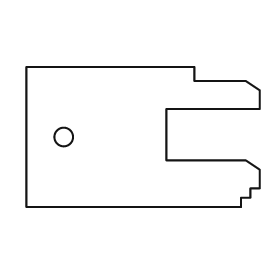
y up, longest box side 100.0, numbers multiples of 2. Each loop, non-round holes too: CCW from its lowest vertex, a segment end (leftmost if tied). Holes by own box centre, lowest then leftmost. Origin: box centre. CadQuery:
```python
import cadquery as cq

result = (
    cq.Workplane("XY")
    .moveTo(-50.0, -30.0)
    .lineTo(42.0, -30.0)
    .lineTo(42.0, -26.0)
    .lineTo(46.0, -26.0)
    .lineTo(46.0, -22.0)
    .lineTo(50.0, -22.0)
    .lineTo(50.0, -14.0)
    .lineTo(44.0, -10.0)
    .lineTo(10.0, -10.0)
    .lineTo(10.0, 12.0)
    .lineTo(50.0, 12.0)
    .lineTo(50.0, 20.0)
    .lineTo(44.0, 24.0)
    .lineTo(22.0, 24.0)
    .lineTo(22.0, 30.0)
    .lineTo(-50.0, 30.0)
    .close()
    .moveTo(-34.0, 0.0)
    .circle(4.0)
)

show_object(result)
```